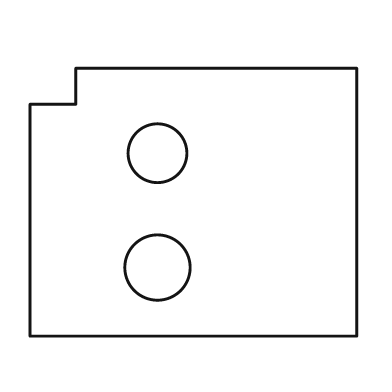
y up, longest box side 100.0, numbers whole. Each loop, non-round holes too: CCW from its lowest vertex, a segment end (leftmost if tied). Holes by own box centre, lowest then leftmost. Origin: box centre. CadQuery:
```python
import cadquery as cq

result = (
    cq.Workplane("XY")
    .moveTo(-50.0, -41.0)
    .lineTo(50.0, -41.0)
    .lineTo(50.0, 41.0)
    .lineTo(-36.0, 41.0)
    .lineTo(-36.0, 30.0)
    .lineTo(-50.0, 30.0)
    .close()
    .moveTo(-11.0, -20.0)
    .circle(10.0)
    .moveTo(-11.0, 15.0)
    .circle(9.0)
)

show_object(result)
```